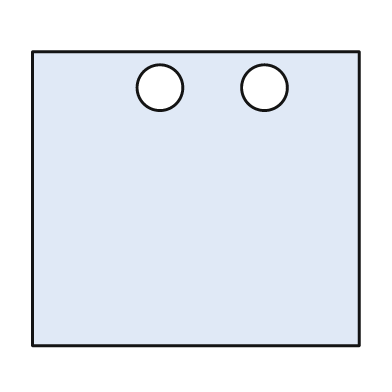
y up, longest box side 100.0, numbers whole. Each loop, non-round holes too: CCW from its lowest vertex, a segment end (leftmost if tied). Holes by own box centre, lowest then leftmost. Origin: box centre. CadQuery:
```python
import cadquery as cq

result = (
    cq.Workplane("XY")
    .moveTo(-50.0, -45.0)
    .lineTo(50.0, -45.0)
    .lineTo(50.0, 45.0)
    .lineTo(-50.0, 45.0)
    .close()
    .moveTo(-11.0, 34.0)
    .circle(7.0)
    .moveTo(21.0, 34.0)
    .circle(7.0)
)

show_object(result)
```